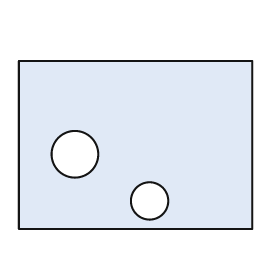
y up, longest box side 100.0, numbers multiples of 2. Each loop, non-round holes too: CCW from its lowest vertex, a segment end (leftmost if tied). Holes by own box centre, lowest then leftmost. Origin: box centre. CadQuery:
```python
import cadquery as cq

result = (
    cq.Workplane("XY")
    .moveTo(-50.0, -36.0)
    .lineTo(50.0, -36.0)
    .lineTo(50.0, 36.0)
    .lineTo(-50.0, 36.0)
    .close()
    .moveTo(6.0, -24.0)
    .circle(8.0)
    .moveTo(-26.0, -4.0)
    .circle(10.0)
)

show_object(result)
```